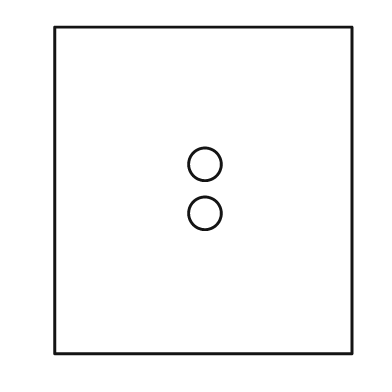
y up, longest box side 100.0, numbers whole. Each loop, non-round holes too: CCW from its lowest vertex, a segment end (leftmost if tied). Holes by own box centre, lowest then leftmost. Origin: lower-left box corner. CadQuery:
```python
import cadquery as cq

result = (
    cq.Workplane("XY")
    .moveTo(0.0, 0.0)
    .lineTo(91.0, 0.0)
    .lineTo(91.0, 100.0)
    .lineTo(0.0, 100.0)
    .close()
    .moveTo(46.0, 43.0)
    .circle(5.0)
    .moveTo(46.0, 58.0)
    .circle(5.0)
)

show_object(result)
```